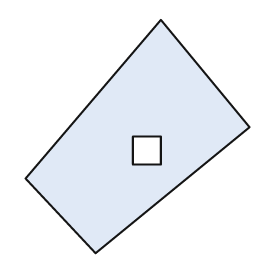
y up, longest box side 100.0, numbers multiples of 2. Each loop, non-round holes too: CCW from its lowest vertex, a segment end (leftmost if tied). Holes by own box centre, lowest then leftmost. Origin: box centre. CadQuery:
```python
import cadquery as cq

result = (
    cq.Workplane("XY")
    .moveTo(-18.0, -50.0)
    .lineTo(48.0, 4.0)
    .lineTo(10.0, 50.0)
    .lineTo(-48.0, -18.0)
    .close()
    .moveTo(-2.0, -12.0)
    .lineTo(10.0, -12.0)
    .lineTo(10.0, 0.0)
    .lineTo(-2.0, 0.0)
    .close()
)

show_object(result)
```